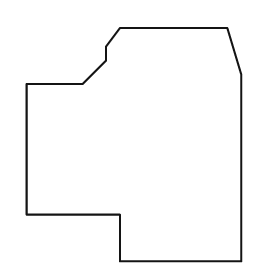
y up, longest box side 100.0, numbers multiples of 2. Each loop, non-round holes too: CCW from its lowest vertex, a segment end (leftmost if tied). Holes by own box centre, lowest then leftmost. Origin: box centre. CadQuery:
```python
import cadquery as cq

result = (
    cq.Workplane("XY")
    .moveTo(-6.0, -50.0)
    .lineTo(46.0, -50.0)
    .lineTo(46.0, 30.0)
    .lineTo(40.0, 50.0)
    .lineTo(-6.0, 50.0)
    .lineTo(-12.0, 42.0)
    .lineTo(-12.0, 36.0)
    .lineTo(-22.0, 26.0)
    .lineTo(-46.0, 26.0)
    .lineTo(-46.0, -30.0)
    .lineTo(-6.0, -30.0)
    .close()
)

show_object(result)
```